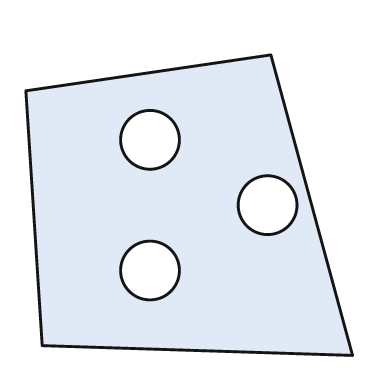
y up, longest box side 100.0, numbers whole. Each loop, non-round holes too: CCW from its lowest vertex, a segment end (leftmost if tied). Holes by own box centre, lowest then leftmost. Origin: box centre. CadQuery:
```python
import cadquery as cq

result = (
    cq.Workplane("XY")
    .moveTo(50.0, -46.0)
    .lineTo(25.0, 46.0)
    .lineTo(-50.0, 35.0)
    .lineTo(-45.0, -43.0)
    .close()
    .moveTo(-12.0, -20.0)
    .circle(9.0)
    .moveTo(24.0, 0.0)
    .circle(9.0)
    .moveTo(-12.0, 20.0)
    .circle(9.0)
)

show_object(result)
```